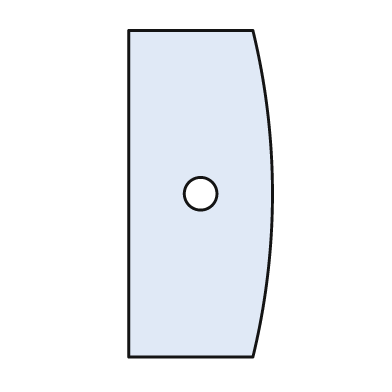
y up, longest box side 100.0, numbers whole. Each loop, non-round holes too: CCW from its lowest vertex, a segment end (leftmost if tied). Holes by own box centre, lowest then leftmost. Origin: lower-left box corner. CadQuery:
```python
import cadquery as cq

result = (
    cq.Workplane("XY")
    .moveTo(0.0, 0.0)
    .lineTo(38.0, 0.0)
    .threePointArc((44.0, 50.0), (38.0, 100.0))
    .lineTo(0.0, 100.0)
    .close()
    .moveTo(22.0, 50.0)
    .circle(5.0)
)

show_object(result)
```